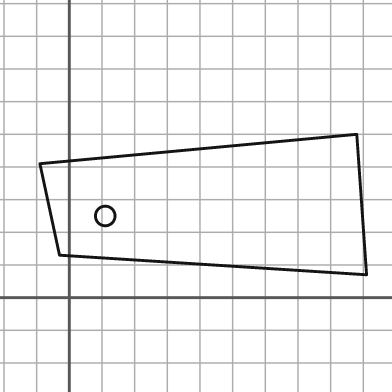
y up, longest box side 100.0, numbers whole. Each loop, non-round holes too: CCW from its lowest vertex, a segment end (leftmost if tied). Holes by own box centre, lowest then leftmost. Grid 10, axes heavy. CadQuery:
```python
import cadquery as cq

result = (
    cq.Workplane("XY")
    .moveTo(91.0, 7.0)
    .lineTo(88.0, 50.0)
    .lineTo(-9.0, 41.0)
    .lineTo(-3.0, 13.0)
    .close()
    .moveTo(11.0, 25.0)
    .circle(3.0)
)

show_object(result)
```